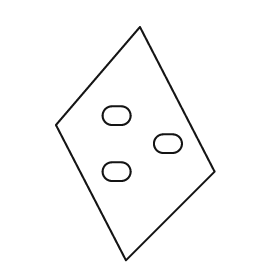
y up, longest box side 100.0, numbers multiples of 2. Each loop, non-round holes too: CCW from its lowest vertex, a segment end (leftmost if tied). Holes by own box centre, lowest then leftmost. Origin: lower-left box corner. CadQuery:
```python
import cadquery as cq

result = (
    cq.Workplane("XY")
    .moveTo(30.0, 0.0)
    .lineTo(68.0, 38.0)
    .lineTo(36.0, 100.0)
    .lineTo(0.0, 58.0)
    .close()
    .moveTo(24.0, 34.0)
    .lineTo(28.0, 34.0)
    .threePointArc((32.0, 38.0), (28.0, 42.0))
    .lineTo(24.0, 42.0)
    .threePointArc((20.0, 38.0), (24.0, 34.0))
    .close()
    .moveTo(46.0, 46.0)
    .lineTo(50.0, 46.0)
    .threePointArc((54.0, 50.0), (50.0, 54.0))
    .lineTo(46.0, 54.0)
    .threePointArc((42.0, 50.0), (46.0, 46.0))
    .close()
    .moveTo(24.0, 58.0)
    .lineTo(28.0, 58.0)
    .threePointArc((32.0, 62.0), (28.0, 66.0))
    .lineTo(24.0, 66.0)
    .threePointArc((20.0, 62.0), (24.0, 58.0))
    .close()
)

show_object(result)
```